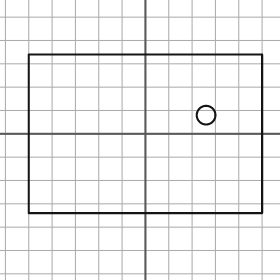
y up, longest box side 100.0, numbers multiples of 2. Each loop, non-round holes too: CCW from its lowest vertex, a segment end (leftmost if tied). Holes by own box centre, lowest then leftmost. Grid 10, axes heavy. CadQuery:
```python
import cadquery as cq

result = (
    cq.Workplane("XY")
    .moveTo(-50.0, -34.0)
    .lineTo(50.0, -34.0)
    .lineTo(50.0, 34.0)
    .lineTo(-50.0, 34.0)
    .close()
    .moveTo(26.0, 8.0)
    .circle(4.0)
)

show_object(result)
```